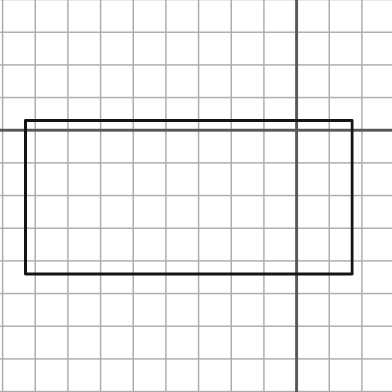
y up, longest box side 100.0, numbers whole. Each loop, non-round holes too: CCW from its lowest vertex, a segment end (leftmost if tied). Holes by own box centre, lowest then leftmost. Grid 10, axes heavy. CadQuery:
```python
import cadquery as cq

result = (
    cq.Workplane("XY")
    .moveTo(-83.0, -44.0)
    .lineTo(17.0, -44.0)
    .lineTo(17.0, 3.0)
    .lineTo(-83.0, 3.0)
    .close()
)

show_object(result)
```